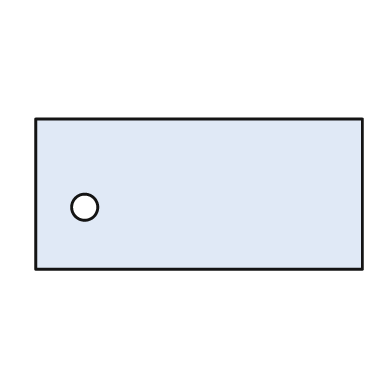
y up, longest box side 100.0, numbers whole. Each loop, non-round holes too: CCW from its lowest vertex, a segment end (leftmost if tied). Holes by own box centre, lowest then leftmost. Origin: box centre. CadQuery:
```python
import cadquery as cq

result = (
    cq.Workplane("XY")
    .moveTo(-50.0, -23.0)
    .lineTo(50.0, -23.0)
    .lineTo(50.0, 23.0)
    .lineTo(-50.0, 23.0)
    .close()
    .moveTo(-35.0, -4.0)
    .circle(4.0)
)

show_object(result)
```